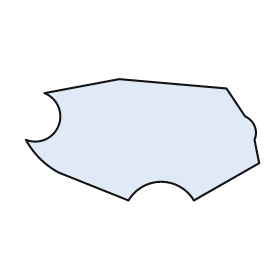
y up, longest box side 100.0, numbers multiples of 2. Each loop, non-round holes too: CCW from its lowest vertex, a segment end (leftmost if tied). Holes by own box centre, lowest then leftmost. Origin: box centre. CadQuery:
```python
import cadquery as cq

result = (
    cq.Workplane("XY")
    .moveTo(-6.0, -26.0)
    .threePointArc((8.0, -18.0), (22.0, -26.0))
    .lineTo(50.0, -10.0)
    .lineTo(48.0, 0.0)
    .threePointArc((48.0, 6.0), (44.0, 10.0))
    .lineTo(36.0, 22.0)
    .lineTo(-10.0, 26.0)
    .lineTo(-42.0, 20.0)
    .threePointArc((-36.0, 6.0), (-50.0, 0.0))
    .threePointArc((-44.0, -8.0), (-36.0, -14.0))
    .close()
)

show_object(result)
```